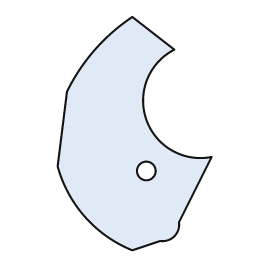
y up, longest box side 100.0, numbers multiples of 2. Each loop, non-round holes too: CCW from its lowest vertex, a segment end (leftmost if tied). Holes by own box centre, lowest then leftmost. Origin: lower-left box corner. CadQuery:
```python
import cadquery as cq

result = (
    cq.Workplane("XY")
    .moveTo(32.0, 0.0)
    .lineTo(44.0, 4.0)
    .threePointArc((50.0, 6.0), (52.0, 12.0))
    .lineTo(66.0, 40.0)
    .threePointArc((38.0, 56.0), (50.0, 86.0))
    .lineTo(32.0, 100.0)
    .threePointArc((16.0, 86.0), (4.0, 68.0))
    .lineTo(0.0, 36.0)
    .threePointArc((12.0, 14.0), (32.0, 0.0))
    .close()
    .moveTo(38.0, 34.0)
    .circle(4.0)
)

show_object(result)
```